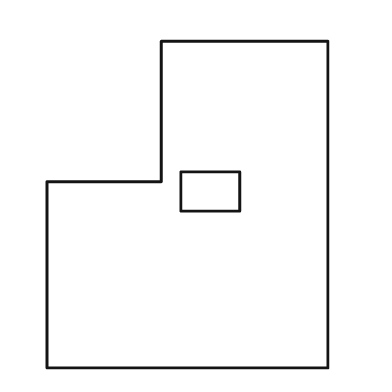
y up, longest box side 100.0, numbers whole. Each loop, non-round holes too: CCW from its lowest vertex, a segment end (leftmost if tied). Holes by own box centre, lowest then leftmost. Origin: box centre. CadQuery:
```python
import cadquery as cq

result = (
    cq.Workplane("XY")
    .moveTo(-43.0, -50.0)
    .lineTo(43.0, -50.0)
    .lineTo(43.0, 50.0)
    .lineTo(-8.0, 50.0)
    .lineTo(-8.0, 7.0)
    .lineTo(-43.0, 7.0)
    .close()
    .moveTo(-2.0, -2.0)
    .lineTo(16.0, -2.0)
    .lineTo(16.0, 10.0)
    .lineTo(-2.0, 10.0)
    .close()
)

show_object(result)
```